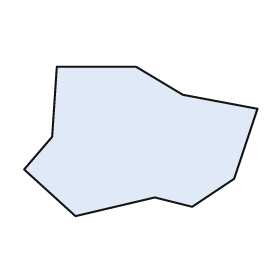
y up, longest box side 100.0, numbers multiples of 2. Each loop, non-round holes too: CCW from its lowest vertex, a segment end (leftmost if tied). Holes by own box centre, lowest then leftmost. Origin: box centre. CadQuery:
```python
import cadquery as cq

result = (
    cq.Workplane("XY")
    .moveTo(-28.0, -32.0)
    .lineTo(6.0, -24.0)
    .lineTo(22.0, -28.0)
    .lineTo(40.0, -16.0)
    .lineTo(50.0, 14.0)
    .lineTo(18.0, 20.0)
    .lineTo(-2.0, 32.0)
    .lineTo(-36.0, 32.0)
    .lineTo(-38.0, 2.0)
    .lineTo(-50.0, -12.0)
    .close()
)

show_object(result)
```